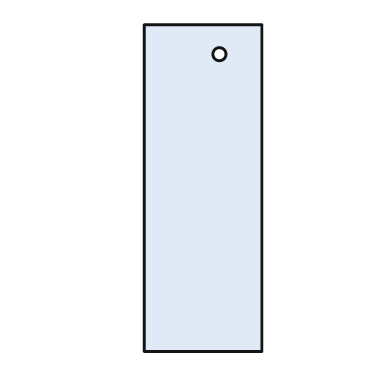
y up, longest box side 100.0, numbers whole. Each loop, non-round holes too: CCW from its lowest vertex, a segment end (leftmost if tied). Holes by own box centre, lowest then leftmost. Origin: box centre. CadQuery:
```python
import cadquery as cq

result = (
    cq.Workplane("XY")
    .moveTo(-18.0, -50.0)
    .lineTo(18.0, -50.0)
    .lineTo(18.0, 50.0)
    .lineTo(-18.0, 50.0)
    .close()
    .moveTo(5.0, 41.0)
    .circle(2.0)
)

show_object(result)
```